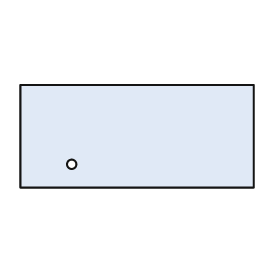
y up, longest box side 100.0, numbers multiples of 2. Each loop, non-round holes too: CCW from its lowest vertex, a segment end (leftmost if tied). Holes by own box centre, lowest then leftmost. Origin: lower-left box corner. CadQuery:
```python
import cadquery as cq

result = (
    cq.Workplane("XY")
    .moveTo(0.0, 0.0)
    .lineTo(100.0, 0.0)
    .lineTo(100.0, 44.0)
    .lineTo(0.0, 44.0)
    .close()
    .moveTo(22.0, 10.0)
    .circle(2.0)
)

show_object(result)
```